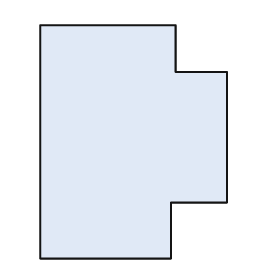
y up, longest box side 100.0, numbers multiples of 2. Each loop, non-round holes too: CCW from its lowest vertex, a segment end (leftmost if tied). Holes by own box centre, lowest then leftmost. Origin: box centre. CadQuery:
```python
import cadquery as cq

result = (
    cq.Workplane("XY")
    .moveTo(-40.0, -50.0)
    .lineTo(16.0, -50.0)
    .lineTo(16.0, -26.0)
    .lineTo(40.0, -26.0)
    .lineTo(40.0, 30.0)
    .lineTo(18.0, 30.0)
    .lineTo(18.0, 50.0)
    .lineTo(-40.0, 50.0)
    .close()
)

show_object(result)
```